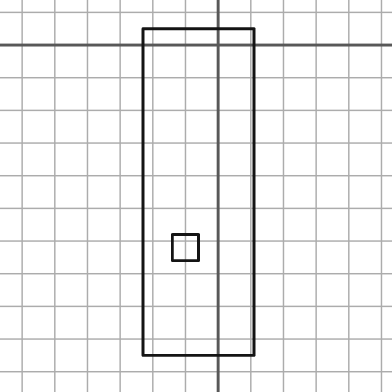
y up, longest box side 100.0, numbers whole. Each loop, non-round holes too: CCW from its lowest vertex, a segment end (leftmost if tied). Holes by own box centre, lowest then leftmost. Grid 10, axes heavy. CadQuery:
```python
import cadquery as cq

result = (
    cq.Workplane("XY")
    .moveTo(-23.0, -95.0)
    .lineTo(11.0, -95.0)
    .lineTo(11.0, 5.0)
    .lineTo(-23.0, 5.0)
    .close()
    .moveTo(-14.0, -66.0)
    .lineTo(-6.0, -66.0)
    .lineTo(-6.0, -58.0)
    .lineTo(-14.0, -58.0)
    .close()
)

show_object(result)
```